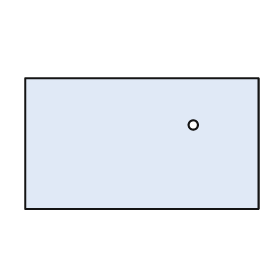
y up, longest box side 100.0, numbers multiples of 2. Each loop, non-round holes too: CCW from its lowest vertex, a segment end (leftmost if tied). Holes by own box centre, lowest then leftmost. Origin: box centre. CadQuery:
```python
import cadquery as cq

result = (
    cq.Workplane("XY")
    .moveTo(-50.0, -28.0)
    .lineTo(50.0, -28.0)
    .lineTo(50.0, 28.0)
    .lineTo(-50.0, 28.0)
    .close()
    .moveTo(22.0, 8.0)
    .circle(2.0)
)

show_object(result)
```